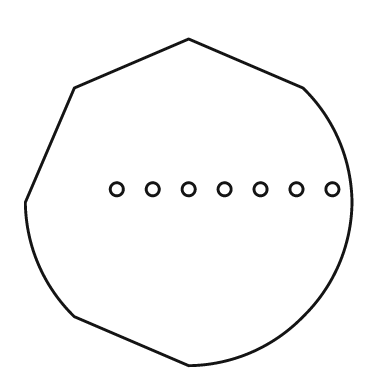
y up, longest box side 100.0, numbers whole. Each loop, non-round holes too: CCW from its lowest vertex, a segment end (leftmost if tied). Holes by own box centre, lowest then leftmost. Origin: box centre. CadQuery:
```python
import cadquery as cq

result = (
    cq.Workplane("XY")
    .moveTo(0.0, -50.0)
    .threePointArc((19.0, -46.0), (35.0, -35.0))
    .threePointArc((46.0, -19.0), (50.0, 0.0))
    .threePointArc((46.0, 19.0), (35.0, 35.0))
    .lineTo(0.0, 50.0)
    .lineTo(-35.0, 35.0)
    .lineTo(-50.0, 0.0)
    .threePointArc((-46.0, -19.0), (-35.0, -35.0))
    .close()
    .moveTo(-22.0, 4.0)
    .circle(2.0)
    .moveTo(-11.0, 4.0)
    .circle(2.0)
    .moveTo(0.0, 4.0)
    .circle(2.0)
    .moveTo(11.0, 4.0)
    .circle(2.0)
    .moveTo(22.0, 4.0)
    .circle(2.0)
    .moveTo(33.0, 4.0)
    .circle(2.0)
    .moveTo(44.0, 4.0)
    .circle(2.0)
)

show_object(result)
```